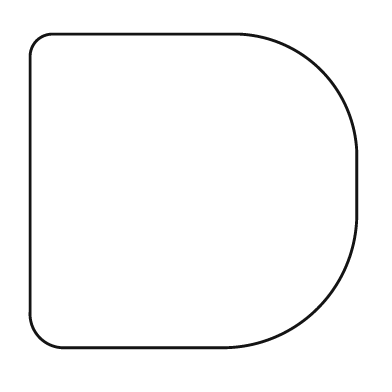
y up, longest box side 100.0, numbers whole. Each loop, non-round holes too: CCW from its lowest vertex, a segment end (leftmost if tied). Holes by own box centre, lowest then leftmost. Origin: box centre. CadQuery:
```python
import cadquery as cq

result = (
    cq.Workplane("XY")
    .moveTo(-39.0, -48.0)
    .lineTo(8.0, -48.0)
    .threePointArc((38.0, -36.0), (50.0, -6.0))
    .lineTo(50.0, 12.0)
    .threePointArc((39.0, 37.0), (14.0, 48.0))
    .lineTo(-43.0, 48.0)
    .threePointArc((-48.0, 46.0), (-50.0, 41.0))
    .lineTo(-50.0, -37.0)
    .threePointArc((-47.0, -45.0), (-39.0, -48.0))
    .close()
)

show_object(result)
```